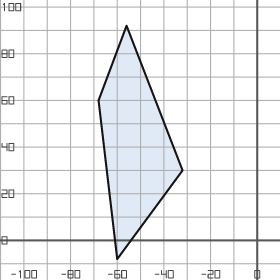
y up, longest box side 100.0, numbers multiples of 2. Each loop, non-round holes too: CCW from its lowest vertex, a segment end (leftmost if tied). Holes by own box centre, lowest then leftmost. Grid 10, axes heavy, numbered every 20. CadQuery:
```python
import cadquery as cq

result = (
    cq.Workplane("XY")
    .moveTo(-60.0, -8.0)
    .lineTo(-32.0, 30.0)
    .lineTo(-56.0, 92.0)
    .lineTo(-68.0, 60.0)
    .close()
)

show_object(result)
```